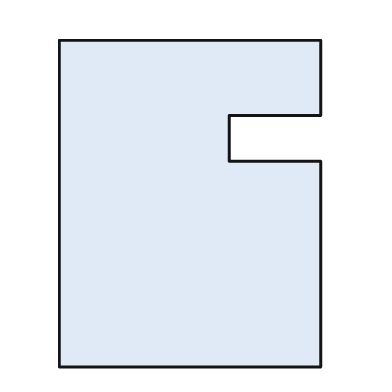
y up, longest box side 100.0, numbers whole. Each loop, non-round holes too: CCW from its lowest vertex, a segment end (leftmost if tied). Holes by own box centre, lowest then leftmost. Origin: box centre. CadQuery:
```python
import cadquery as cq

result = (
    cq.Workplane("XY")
    .moveTo(-40.0, -50.0)
    .lineTo(40.0, -50.0)
    .lineTo(40.0, 13.0)
    .lineTo(12.0, 13.0)
    .lineTo(12.0, 27.0)
    .lineTo(40.0, 27.0)
    .lineTo(40.0, 50.0)
    .lineTo(-40.0, 50.0)
    .close()
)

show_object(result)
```